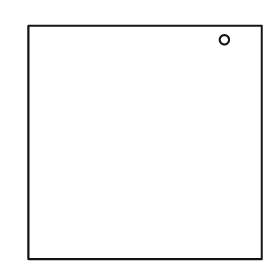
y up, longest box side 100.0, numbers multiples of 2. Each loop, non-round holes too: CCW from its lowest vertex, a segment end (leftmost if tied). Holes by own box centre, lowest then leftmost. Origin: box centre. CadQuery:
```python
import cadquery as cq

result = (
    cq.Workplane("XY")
    .moveTo(-50.0, -50.0)
    .lineTo(50.0, -50.0)
    .lineTo(50.0, 50.0)
    .lineTo(-50.0, 50.0)
    .close()
    .moveTo(34.0, 44.0)
    .circle(2.0)
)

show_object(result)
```